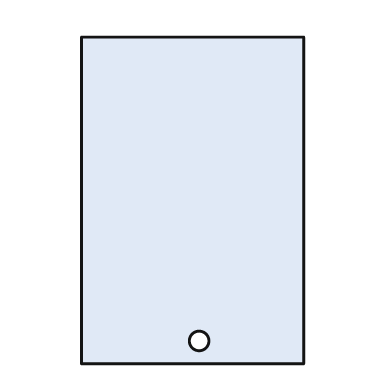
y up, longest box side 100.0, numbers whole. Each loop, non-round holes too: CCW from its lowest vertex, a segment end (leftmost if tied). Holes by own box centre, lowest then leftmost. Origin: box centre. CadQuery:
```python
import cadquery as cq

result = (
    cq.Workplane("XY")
    .moveTo(-34.0, -50.0)
    .lineTo(34.0, -50.0)
    .lineTo(34.0, 50.0)
    .lineTo(-34.0, 50.0)
    .close()
    .moveTo(2.0, -43.0)
    .circle(3.0)
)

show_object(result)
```